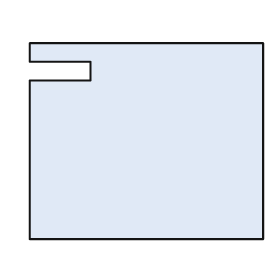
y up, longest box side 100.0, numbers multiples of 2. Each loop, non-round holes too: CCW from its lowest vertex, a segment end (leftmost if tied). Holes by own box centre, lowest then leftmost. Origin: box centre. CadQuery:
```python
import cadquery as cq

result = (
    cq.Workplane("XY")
    .moveTo(-50.0, -42.0)
    .lineTo(50.0, -42.0)
    .lineTo(50.0, 42.0)
    .lineTo(-50.0, 42.0)
    .lineTo(-50.0, 34.0)
    .lineTo(-24.0, 34.0)
    .lineTo(-24.0, 26.0)
    .lineTo(-50.0, 26.0)
    .close()
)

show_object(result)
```